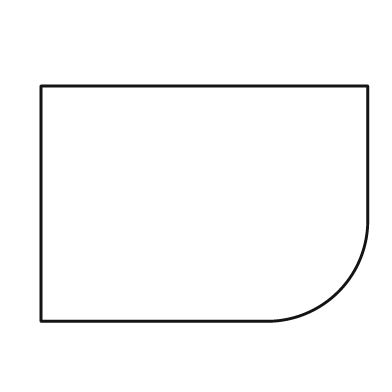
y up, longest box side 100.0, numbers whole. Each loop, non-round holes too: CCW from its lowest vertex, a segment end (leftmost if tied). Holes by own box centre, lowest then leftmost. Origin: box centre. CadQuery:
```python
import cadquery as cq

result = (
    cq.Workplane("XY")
    .moveTo(-50.0, -36.0)
    .lineTo(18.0, -36.0)
    .threePointArc((41.0, -27.0), (50.0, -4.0))
    .lineTo(50.0, 36.0)
    .lineTo(-50.0, 36.0)
    .close()
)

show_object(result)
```